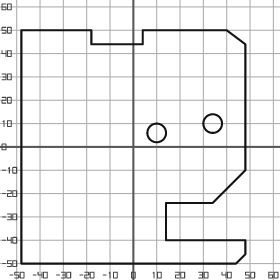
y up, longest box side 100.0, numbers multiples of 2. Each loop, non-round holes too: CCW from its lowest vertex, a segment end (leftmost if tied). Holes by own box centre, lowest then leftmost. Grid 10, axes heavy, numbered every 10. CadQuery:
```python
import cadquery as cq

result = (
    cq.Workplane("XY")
    .moveTo(-48.0, -50.0)
    .lineTo(44.0, -50.0)
    .lineTo(48.0, -46.0)
    .lineTo(48.0, -40.0)
    .lineTo(14.0, -40.0)
    .lineTo(14.0, -24.0)
    .lineTo(34.0, -24.0)
    .lineTo(48.0, -10.0)
    .lineTo(48.0, 44.0)
    .lineTo(40.0, 50.0)
    .lineTo(4.0, 50.0)
    .lineTo(4.0, 44.0)
    .lineTo(-18.0, 44.0)
    .lineTo(-18.0, 50.0)
    .lineTo(-48.0, 50.0)
    .close()
    .moveTo(10.0, 6.0)
    .circle(4.0)
    .moveTo(34.0, 10.0)
    .circle(4.0)
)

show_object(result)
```